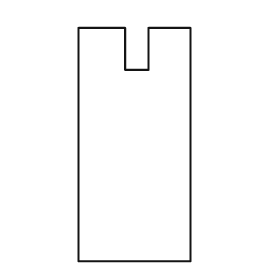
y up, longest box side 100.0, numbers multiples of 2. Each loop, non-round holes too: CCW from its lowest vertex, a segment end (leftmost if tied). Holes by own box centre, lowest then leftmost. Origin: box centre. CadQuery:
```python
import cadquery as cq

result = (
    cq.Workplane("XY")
    .moveTo(-24.0, -50.0)
    .lineTo(24.0, -50.0)
    .lineTo(24.0, 50.0)
    .lineTo(6.0, 50.0)
    .lineTo(6.0, 32.0)
    .lineTo(-4.0, 32.0)
    .lineTo(-4.0, 50.0)
    .lineTo(-24.0, 50.0)
    .close()
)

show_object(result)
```